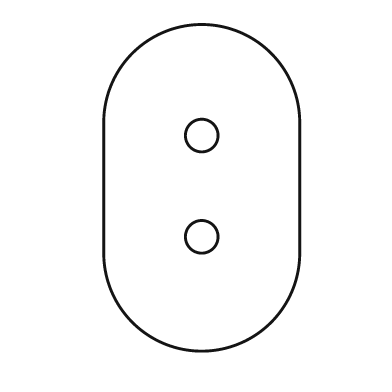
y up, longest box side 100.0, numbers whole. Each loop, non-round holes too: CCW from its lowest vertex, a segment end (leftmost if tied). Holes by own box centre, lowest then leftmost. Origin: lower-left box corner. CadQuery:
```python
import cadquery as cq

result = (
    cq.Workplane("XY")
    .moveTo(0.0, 30.0)
    .threePointArc((30.0, 0.0), (60.0, 30.0))
    .lineTo(60.0, 70.0)
    .threePointArc((30.0, 100.0), (0.0, 70.0))
    .close()
    .moveTo(30.0, 35.0)
    .circle(5.0)
    .moveTo(30.0, 66.0)
    .circle(5.0)
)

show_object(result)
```